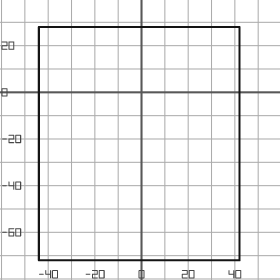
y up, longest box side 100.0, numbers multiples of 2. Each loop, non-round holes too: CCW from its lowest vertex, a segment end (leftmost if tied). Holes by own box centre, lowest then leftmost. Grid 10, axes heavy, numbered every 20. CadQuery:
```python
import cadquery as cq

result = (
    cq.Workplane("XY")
    .moveTo(-44.0, -72.0)
    .lineTo(42.0, -72.0)
    .lineTo(42.0, 28.0)
    .lineTo(-44.0, 28.0)
    .close()
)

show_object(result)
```